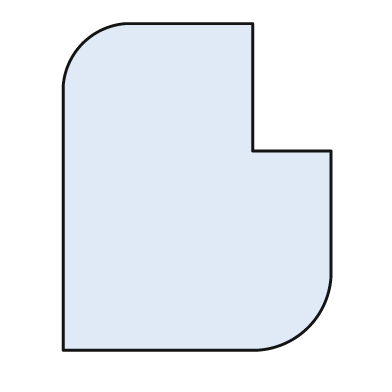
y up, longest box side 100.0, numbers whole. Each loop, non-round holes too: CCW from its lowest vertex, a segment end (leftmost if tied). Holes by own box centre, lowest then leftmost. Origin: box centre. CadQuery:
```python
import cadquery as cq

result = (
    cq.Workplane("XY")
    .moveTo(-41.0, -50.0)
    .lineTo(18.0, -50.0)
    .threePointArc((34.0, -43.0), (41.0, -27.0))
    .lineTo(41.0, 11.0)
    .lineTo(17.0, 11.0)
    .lineTo(17.0, 50.0)
    .lineTo(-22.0, 50.0)
    .threePointArc((-35.0, 44.0), (-41.0, 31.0))
    .close()
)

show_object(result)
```